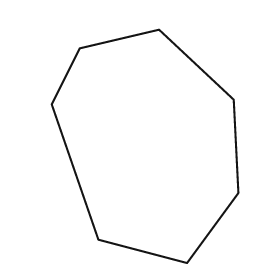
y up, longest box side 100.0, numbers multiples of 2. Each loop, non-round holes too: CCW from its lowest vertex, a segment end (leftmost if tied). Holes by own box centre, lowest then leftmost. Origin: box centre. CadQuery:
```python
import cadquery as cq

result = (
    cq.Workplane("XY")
    .moveTo(18.0, -50.0)
    .lineTo(40.0, -20.0)
    .lineTo(38.0, 20.0)
    .lineTo(6.0, 50.0)
    .lineTo(-28.0, 42.0)
    .lineTo(-40.0, 18.0)
    .lineTo(-20.0, -40.0)
    .close()
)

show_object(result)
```